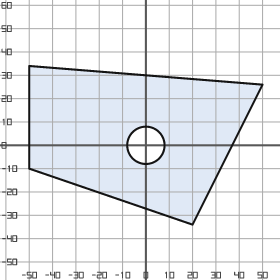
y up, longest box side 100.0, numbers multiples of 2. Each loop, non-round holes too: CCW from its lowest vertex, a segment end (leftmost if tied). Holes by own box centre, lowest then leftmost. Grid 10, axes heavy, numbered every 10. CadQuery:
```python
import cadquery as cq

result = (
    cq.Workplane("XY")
    .moveTo(20.0, -34.0)
    .lineTo(50.0, 26.0)
    .lineTo(-50.0, 34.0)
    .lineTo(-50.0, -10.0)
    .close()
    .moveTo(0.0, 0.0)
    .circle(8.0)
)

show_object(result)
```